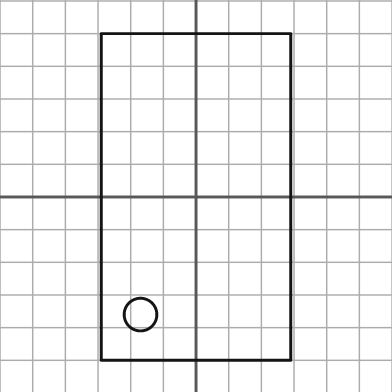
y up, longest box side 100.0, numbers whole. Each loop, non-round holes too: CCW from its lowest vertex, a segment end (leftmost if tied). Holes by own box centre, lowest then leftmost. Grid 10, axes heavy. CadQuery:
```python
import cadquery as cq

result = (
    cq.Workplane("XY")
    .moveTo(-29.0, -50.0)
    .lineTo(29.0, -50.0)
    .lineTo(29.0, 50.0)
    .lineTo(-29.0, 50.0)
    .close()
    .moveTo(-17.0, -36.0)
    .circle(5.0)
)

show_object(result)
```